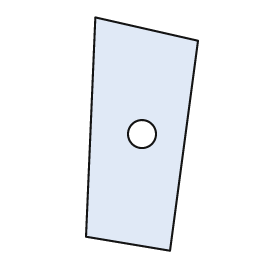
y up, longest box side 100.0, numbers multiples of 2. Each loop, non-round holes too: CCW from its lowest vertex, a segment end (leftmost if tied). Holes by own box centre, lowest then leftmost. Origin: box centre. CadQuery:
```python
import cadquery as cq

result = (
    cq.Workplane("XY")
    .moveTo(12.0, -50.0)
    .lineTo(24.0, 40.0)
    .lineTo(-20.0, 50.0)
    .lineTo(-24.0, -44.0)
    .close()
    .moveTo(0.0, 0.0)
    .circle(6.0)
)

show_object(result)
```